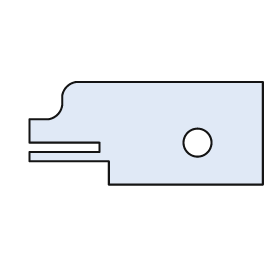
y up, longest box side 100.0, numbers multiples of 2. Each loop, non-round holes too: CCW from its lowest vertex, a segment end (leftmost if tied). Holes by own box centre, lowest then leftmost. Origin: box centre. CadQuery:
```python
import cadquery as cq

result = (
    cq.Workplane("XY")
    .moveTo(-16.0, -22.0)
    .lineTo(50.0, -22.0)
    .lineTo(50.0, 22.0)
    .lineTo(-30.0, 22.0)
    .threePointArc((-34.0, 20.0), (-36.0, 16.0))
    .lineTo(-36.0, 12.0)
    .threePointArc((-38.0, 8.0), (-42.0, 6.0))
    .lineTo(-50.0, 6.0)
    .lineTo(-50.0, -4.0)
    .lineTo(-20.0, -4.0)
    .lineTo(-20.0, -8.0)
    .lineTo(-50.0, -8.0)
    .lineTo(-50.0, -12.0)
    .lineTo(-16.0, -12.0)
    .close()
    .moveTo(22.0, -4.0)
    .circle(6.0)
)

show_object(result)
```